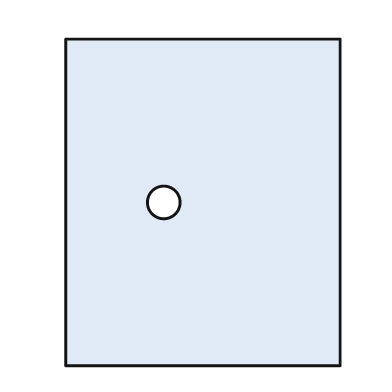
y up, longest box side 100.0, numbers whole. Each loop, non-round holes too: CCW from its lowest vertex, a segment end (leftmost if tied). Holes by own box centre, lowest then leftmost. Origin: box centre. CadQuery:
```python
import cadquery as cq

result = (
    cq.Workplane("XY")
    .moveTo(-42.0, -50.0)
    .lineTo(42.0, -50.0)
    .lineTo(42.0, 50.0)
    .lineTo(-42.0, 50.0)
    .close()
    .moveTo(-12.0, 0.0)
    .circle(5.0)
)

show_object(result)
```